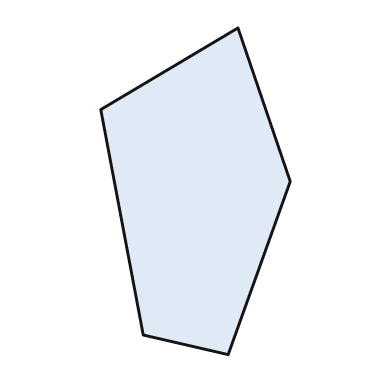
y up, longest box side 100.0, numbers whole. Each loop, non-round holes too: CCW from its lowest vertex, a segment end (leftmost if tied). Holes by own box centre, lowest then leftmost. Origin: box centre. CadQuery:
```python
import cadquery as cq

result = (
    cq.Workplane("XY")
    .moveTo(10.0, -50.0)
    .lineTo(29.0, 3.0)
    .lineTo(13.0, 50.0)
    .lineTo(-29.0, 25.0)
    .lineTo(-16.0, -44.0)
    .close()
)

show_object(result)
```